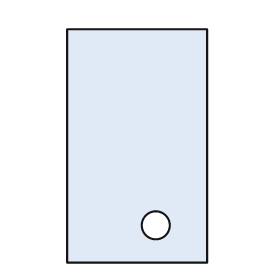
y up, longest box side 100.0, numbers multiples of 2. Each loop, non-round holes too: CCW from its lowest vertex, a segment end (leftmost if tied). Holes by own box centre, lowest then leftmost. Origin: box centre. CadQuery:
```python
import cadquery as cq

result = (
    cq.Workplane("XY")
    .moveTo(-30.0, -50.0)
    .lineTo(30.0, -50.0)
    .lineTo(30.0, 50.0)
    .lineTo(-30.0, 50.0)
    .close()
    .moveTo(8.0, -34.0)
    .circle(6.0)
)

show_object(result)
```